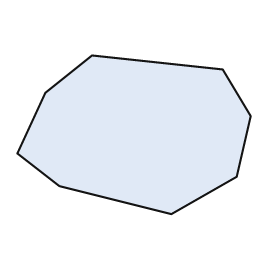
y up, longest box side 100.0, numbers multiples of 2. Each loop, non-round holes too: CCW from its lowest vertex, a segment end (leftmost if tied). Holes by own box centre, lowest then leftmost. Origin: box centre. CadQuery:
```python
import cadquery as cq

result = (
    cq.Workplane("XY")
    .moveTo(16.0, -34.0)
    .lineTo(44.0, -18.0)
    .lineTo(50.0, 8.0)
    .lineTo(38.0, 28.0)
    .lineTo(-18.0, 34.0)
    .lineTo(-38.0, 18.0)
    .lineTo(-50.0, -8.0)
    .lineTo(-32.0, -22.0)
    .close()
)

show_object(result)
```